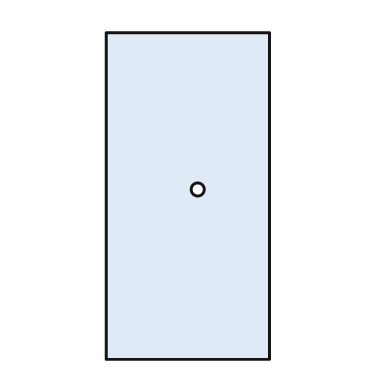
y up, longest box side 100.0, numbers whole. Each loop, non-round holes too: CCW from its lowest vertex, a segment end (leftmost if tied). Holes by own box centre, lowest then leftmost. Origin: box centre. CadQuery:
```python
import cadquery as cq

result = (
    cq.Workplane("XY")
    .moveTo(-25.0, -50.0)
    .lineTo(25.0, -50.0)
    .lineTo(25.0, 50.0)
    .lineTo(-25.0, 50.0)
    .close()
    .moveTo(3.0, 2.0)
    .circle(2.0)
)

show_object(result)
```